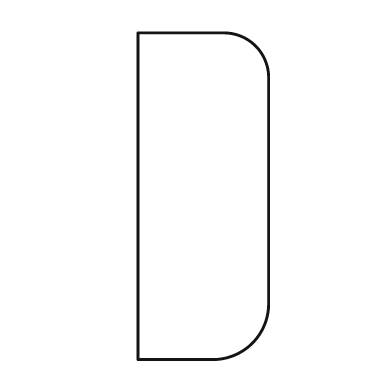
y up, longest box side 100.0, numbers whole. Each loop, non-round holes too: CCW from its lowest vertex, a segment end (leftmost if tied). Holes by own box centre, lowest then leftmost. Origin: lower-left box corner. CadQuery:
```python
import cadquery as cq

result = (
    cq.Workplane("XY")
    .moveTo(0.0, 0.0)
    .lineTo(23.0, 0.0)
    .threePointArc((35.0, 5.0), (40.0, 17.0))
    .lineTo(40.0, 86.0)
    .threePointArc((36.0, 96.0), (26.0, 100.0))
    .lineTo(0.0, 100.0)
    .close()
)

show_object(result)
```